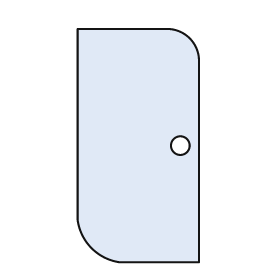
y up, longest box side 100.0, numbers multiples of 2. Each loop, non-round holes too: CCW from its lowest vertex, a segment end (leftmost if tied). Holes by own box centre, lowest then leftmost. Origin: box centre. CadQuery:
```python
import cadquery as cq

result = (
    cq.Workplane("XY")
    .moveTo(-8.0, -50.0)
    .lineTo(26.0, -50.0)
    .lineTo(26.0, 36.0)
    .threePointArc((22.0, 46.0), (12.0, 50.0))
    .lineTo(-26.0, 50.0)
    .lineTo(-26.0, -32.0)
    .threePointArc((-20.0, -44.0), (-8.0, -50.0))
    .close()
    .moveTo(18.0, 0.0)
    .circle(4.0)
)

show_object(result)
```